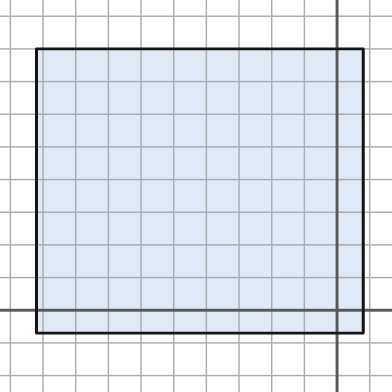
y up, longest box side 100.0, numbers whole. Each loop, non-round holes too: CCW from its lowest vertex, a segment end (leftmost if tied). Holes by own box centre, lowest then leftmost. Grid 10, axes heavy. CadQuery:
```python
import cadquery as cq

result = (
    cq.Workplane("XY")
    .moveTo(-92.0, -7.0)
    .lineTo(8.0, -7.0)
    .lineTo(8.0, 80.0)
    .lineTo(-92.0, 80.0)
    .close()
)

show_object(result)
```